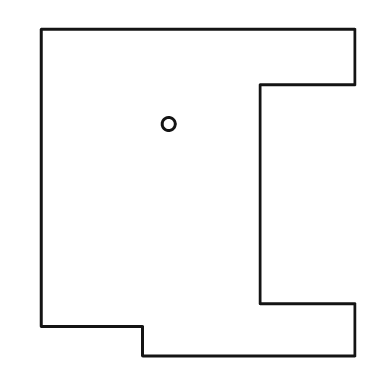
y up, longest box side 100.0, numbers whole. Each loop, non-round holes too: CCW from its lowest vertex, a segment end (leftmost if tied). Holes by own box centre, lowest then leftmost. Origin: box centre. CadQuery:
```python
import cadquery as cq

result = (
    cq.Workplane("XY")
    .moveTo(-17.0, -50.0)
    .lineTo(48.0, -50.0)
    .lineTo(48.0, -34.0)
    .lineTo(19.0, -34.0)
    .lineTo(19.0, 33.0)
    .lineTo(48.0, 33.0)
    .lineTo(48.0, 50.0)
    .lineTo(-48.0, 50.0)
    .lineTo(-48.0, -41.0)
    .lineTo(-17.0, -41.0)
    .close()
    .moveTo(-9.0, 21.0)
    .circle(2.0)
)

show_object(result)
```